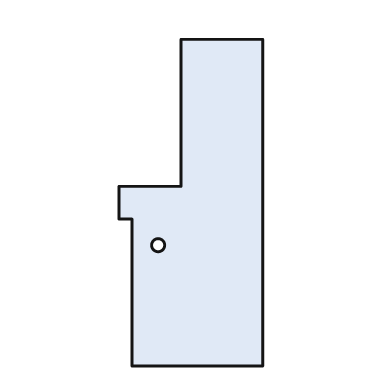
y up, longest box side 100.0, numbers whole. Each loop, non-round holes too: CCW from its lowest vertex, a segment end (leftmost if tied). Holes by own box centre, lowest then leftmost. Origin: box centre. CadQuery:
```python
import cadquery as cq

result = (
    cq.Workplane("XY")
    .moveTo(-18.0, -50.0)
    .lineTo(22.0, -50.0)
    .lineTo(22.0, 50.0)
    .lineTo(-3.0, 50.0)
    .lineTo(-3.0, 5.0)
    .lineTo(-22.0, 5.0)
    .lineTo(-22.0, -5.0)
    .lineTo(-18.0, -5.0)
    .close()
    .moveTo(-10.0, -13.0)
    .circle(2.0)
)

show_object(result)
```